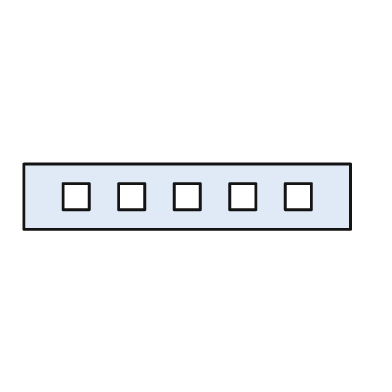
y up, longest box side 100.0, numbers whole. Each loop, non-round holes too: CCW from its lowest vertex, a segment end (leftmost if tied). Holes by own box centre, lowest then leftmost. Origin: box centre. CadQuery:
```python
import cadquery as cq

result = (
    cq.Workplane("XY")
    .moveTo(-50.0, -10.0)
    .lineTo(50.0, -10.0)
    .lineTo(50.0, 10.0)
    .lineTo(-50.0, 10.0)
    .close()
    .moveTo(-38.0, -4.0)
    .lineTo(-30.0, -4.0)
    .lineTo(-30.0, 4.0)
    .lineTo(-38.0, 4.0)
    .close()
    .moveTo(-21.0, -4.0)
    .lineTo(-13.0, -4.0)
    .lineTo(-13.0, 4.0)
    .lineTo(-21.0, 4.0)
    .close()
    .moveTo(-4.0, -4.0)
    .lineTo(4.0, -4.0)
    .lineTo(4.0, 4.0)
    .lineTo(-4.0, 4.0)
    .close()
    .moveTo(13.0, -4.0)
    .lineTo(21.0, -4.0)
    .lineTo(21.0, 4.0)
    .lineTo(13.0, 4.0)
    .close()
    .moveTo(30.0, -4.0)
    .lineTo(38.0, -4.0)
    .lineTo(38.0, 4.0)
    .lineTo(30.0, 4.0)
    .close()
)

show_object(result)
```